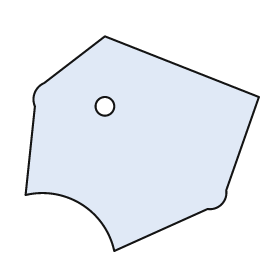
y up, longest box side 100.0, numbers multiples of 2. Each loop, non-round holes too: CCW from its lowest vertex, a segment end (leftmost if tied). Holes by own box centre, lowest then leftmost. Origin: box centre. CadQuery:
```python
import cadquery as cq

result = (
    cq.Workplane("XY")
    .moveTo(-12.0, -46.0)
    .lineTo(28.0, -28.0)
    .threePointArc((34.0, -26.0), (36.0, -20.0))
    .lineTo(50.0, 20.0)
    .lineTo(-16.0, 46.0)
    .lineTo(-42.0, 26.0)
    .threePointArc((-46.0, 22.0), (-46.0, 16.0))
    .lineTo(-50.0, -22.0)
    .threePointArc((-26.0, -26.0), (-12.0, -46.0))
    .close()
    .moveTo(-16.0, 16.0)
    .circle(4.0)
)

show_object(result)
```